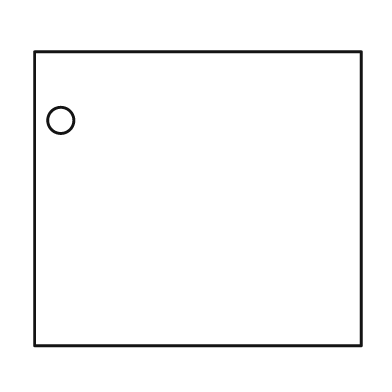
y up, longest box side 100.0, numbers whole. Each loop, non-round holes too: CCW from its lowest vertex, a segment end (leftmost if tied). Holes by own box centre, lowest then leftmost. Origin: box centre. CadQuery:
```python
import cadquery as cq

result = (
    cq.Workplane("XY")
    .moveTo(-50.0, -45.0)
    .lineTo(50.0, -45.0)
    .lineTo(50.0, 45.0)
    .lineTo(-50.0, 45.0)
    .close()
    .moveTo(-42.0, 24.0)
    .circle(4.0)
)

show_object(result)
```